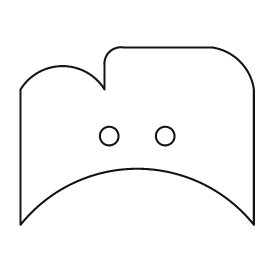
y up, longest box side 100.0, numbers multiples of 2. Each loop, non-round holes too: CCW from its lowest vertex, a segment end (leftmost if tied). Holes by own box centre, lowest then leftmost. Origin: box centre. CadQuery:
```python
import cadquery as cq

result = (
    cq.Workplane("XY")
    .moveTo(-50.0, -38.0)
    .threePointArc((0.0, -14.0), (50.0, -38.0))
    .lineTo(50.0, 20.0)
    .threePointArc((44.0, 32.0), (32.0, 38.0))
    .lineTo(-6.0, 38.0)
    .threePointArc((-12.0, 36.0), (-14.0, 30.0))
    .lineTo(-14.0, 20.0)
    .threePointArc((-32.0, 30.0), (-50.0, 20.0))
    .close()
    .moveTo(-12.0, 0.0)
    .circle(4.0)
    .moveTo(12.0, 0.0)
    .circle(4.0)
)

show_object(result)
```